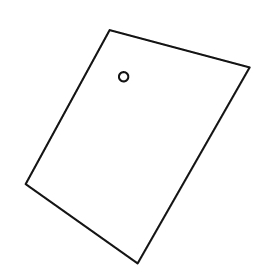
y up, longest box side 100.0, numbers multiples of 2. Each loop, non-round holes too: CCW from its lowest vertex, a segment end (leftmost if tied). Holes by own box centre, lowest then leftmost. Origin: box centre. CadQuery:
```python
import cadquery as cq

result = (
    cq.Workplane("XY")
    .moveTo(0.0, -50.0)
    .lineTo(48.0, 34.0)
    .lineTo(-12.0, 50.0)
    .lineTo(-48.0, -16.0)
    .close()
    .moveTo(-6.0, 30.0)
    .circle(2.0)
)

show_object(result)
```